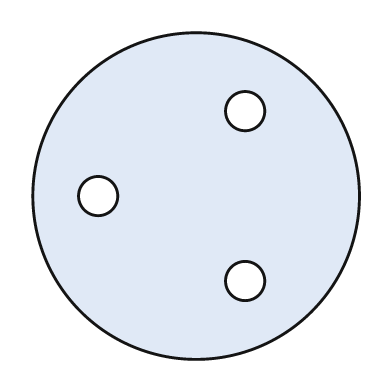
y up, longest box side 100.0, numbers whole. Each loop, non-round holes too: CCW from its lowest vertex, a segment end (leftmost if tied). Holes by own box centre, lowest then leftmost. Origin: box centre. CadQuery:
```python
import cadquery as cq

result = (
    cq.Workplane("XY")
    .moveTo(0.0, 0.0)
    .circle(50.0)
    .moveTo(15.0, -26.0)
    .circle(6.0)
    .moveTo(-30.0, 0.0)
    .circle(6.0)
    .moveTo(15.0, 26.0)
    .circle(6.0)
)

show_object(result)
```